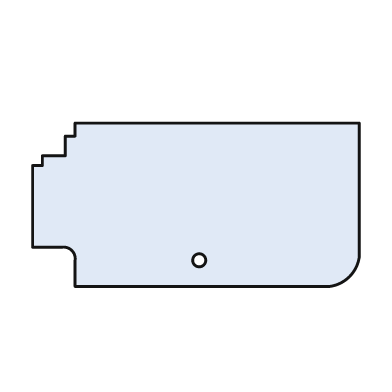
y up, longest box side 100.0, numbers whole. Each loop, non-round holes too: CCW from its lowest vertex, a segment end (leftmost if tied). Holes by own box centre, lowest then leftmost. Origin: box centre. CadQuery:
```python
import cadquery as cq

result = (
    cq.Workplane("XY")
    .moveTo(-37.0, -25.0)
    .lineTo(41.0, -25.0)
    .threePointArc((47.0, -22.0), (50.0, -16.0))
    .lineTo(50.0, 25.0)
    .lineTo(-37.0, 25.0)
    .lineTo(-37.0, 21.0)
    .lineTo(-40.0, 21.0)
    .lineTo(-40.0, 15.0)
    .lineTo(-47.0, 15.0)
    .lineTo(-47.0, 12.0)
    .lineTo(-50.0, 12.0)
    .lineTo(-50.0, -13.0)
    .lineTo(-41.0, -13.0)
    .threePointArc((-38.0, -14.0), (-37.0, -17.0))
    .close()
    .moveTo(1.0, -17.0)
    .circle(2.0)
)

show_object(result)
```